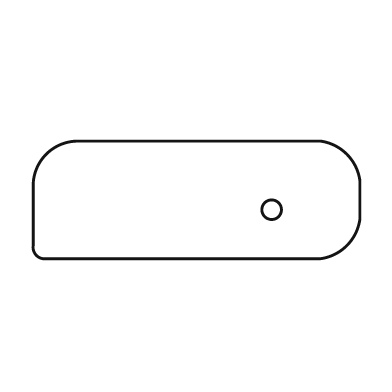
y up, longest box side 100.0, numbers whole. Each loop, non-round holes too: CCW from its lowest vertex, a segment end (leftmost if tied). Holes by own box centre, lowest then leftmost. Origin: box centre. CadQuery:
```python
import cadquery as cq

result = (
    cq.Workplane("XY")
    .moveTo(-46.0, -18.0)
    .lineTo(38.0, -18.0)
    .threePointArc((46.0, -14.0), (50.0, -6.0))
    .lineTo(50.0, 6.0)
    .threePointArc((46.0, 14.0), (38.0, 18.0))
    .lineTo(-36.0, 18.0)
    .threePointArc((-46.0, 14.0), (-50.0, 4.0))
    .lineTo(-50.0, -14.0)
    .threePointArc((-49.0, -17.0), (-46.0, -18.0))
    .close()
    .moveTo(23.0, -3.0)
    .circle(3.0)
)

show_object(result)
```